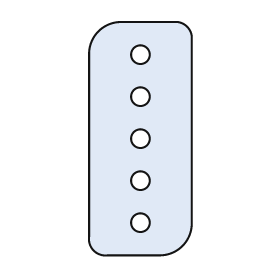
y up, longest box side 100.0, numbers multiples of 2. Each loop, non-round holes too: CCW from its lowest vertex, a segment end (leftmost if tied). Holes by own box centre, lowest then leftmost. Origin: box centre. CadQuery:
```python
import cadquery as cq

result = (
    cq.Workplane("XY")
    .moveTo(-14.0, -50.0)
    .lineTo(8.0, -50.0)
    .threePointArc((18.0, -46.0), (22.0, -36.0))
    .lineTo(22.0, 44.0)
    .threePointArc((20.0, 48.0), (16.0, 50.0))
    .lineTo(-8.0, 50.0)
    .threePointArc((-18.0, 46.0), (-22.0, 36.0))
    .lineTo(-22.0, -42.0)
    .threePointArc((-20.0, -48.0), (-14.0, -50.0))
    .close()
    .moveTo(0.0, -36.0)
    .circle(4.0)
    .moveTo(0.0, -18.0)
    .circle(4.0)
    .moveTo(0.0, 0.0)
    .circle(4.0)
    .moveTo(0.0, 18.0)
    .circle(4.0)
    .moveTo(0.0, 36.0)
    .circle(4.0)
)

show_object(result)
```